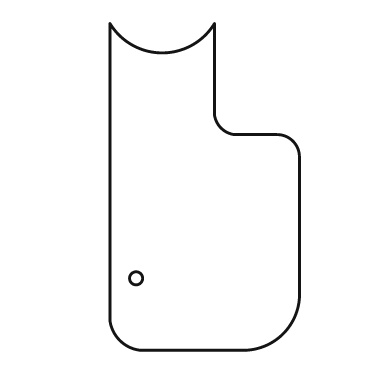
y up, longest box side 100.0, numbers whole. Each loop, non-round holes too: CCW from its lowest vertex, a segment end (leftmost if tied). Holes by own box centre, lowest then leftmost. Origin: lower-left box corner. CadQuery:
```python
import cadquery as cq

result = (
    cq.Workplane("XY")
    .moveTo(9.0, 0.0)
    .lineTo(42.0, 0.0)
    .threePointArc((53.0, 5.0), (58.0, 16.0))
    .lineTo(58.0, 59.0)
    .threePointArc((56.0, 64.0), (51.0, 66.0))
    .lineTo(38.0, 66.0)
    .threePointArc((34.0, 68.0), (32.0, 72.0))
    .lineTo(32.0, 100.0)
    .threePointArc((16.0, 91.0), (0.0, 100.0))
    .lineTo(0.0, 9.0)
    .threePointArc((3.0, 3.0), (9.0, 0.0))
    .close()
    .moveTo(8.0, 22.0)
    .circle(2.0)
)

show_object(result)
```